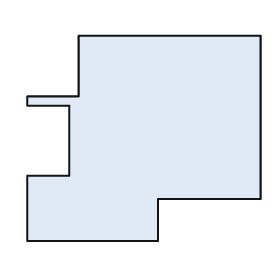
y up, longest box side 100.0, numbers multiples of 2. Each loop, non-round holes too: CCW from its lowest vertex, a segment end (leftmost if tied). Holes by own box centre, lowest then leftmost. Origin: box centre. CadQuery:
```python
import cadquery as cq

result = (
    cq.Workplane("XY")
    .moveTo(-50.0, -44.0)
    .lineTo(6.0, -44.0)
    .lineTo(6.0, -26.0)
    .lineTo(50.0, -26.0)
    .lineTo(50.0, 44.0)
    .lineTo(-28.0, 44.0)
    .lineTo(-28.0, 18.0)
    .lineTo(-50.0, 18.0)
    .lineTo(-50.0, 14.0)
    .lineTo(-32.0, 14.0)
    .lineTo(-32.0, -16.0)
    .lineTo(-50.0, -16.0)
    .close()
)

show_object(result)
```